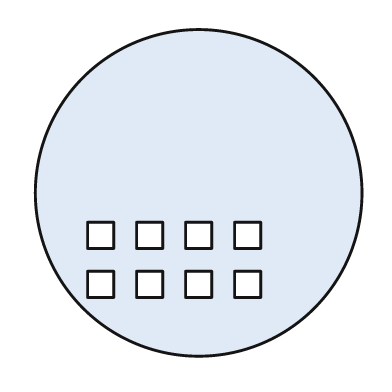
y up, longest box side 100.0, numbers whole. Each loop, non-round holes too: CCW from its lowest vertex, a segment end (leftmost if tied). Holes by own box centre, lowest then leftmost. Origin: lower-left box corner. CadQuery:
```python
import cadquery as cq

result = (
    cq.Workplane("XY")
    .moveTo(50.0, 50.0)
    .circle(50.0)
    .moveTo(16.0, 18.0)
    .lineTo(24.0, 18.0)
    .lineTo(24.0, 26.0)
    .lineTo(16.0, 26.0)
    .close()
    .moveTo(31.0, 18.0)
    .lineTo(39.0, 18.0)
    .lineTo(39.0, 26.0)
    .lineTo(31.0, 26.0)
    .close()
    .moveTo(46.0, 18.0)
    .lineTo(54.0, 18.0)
    .lineTo(54.0, 26.0)
    .lineTo(46.0, 26.0)
    .close()
    .moveTo(61.0, 18.0)
    .lineTo(69.0, 18.0)
    .lineTo(69.0, 26.0)
    .lineTo(61.0, 26.0)
    .close()
    .moveTo(16.0, 33.0)
    .lineTo(24.0, 33.0)
    .lineTo(24.0, 41.0)
    .lineTo(16.0, 41.0)
    .close()
    .moveTo(31.0, 33.0)
    .lineTo(39.0, 33.0)
    .lineTo(39.0, 41.0)
    .lineTo(31.0, 41.0)
    .close()
    .moveTo(46.0, 33.0)
    .lineTo(54.0, 33.0)
    .lineTo(54.0, 41.0)
    .lineTo(46.0, 41.0)
    .close()
    .moveTo(61.0, 33.0)
    .lineTo(69.0, 33.0)
    .lineTo(69.0, 41.0)
    .lineTo(61.0, 41.0)
    .close()
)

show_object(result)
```